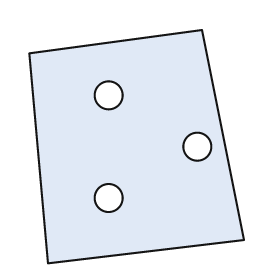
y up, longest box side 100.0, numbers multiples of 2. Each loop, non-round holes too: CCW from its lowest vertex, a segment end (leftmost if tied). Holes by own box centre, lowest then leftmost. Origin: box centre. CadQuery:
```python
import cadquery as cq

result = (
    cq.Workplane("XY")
    .moveTo(-38.0, -50.0)
    .lineTo(46.0, -40.0)
    .lineTo(28.0, 50.0)
    .lineTo(-46.0, 40.0)
    .close()
    .moveTo(-12.0, -22.0)
    .circle(6.0)
    .moveTo(26.0, 0.0)
    .circle(6.0)
    .moveTo(-12.0, 22.0)
    .circle(6.0)
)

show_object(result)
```